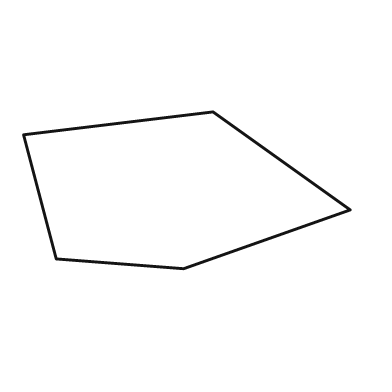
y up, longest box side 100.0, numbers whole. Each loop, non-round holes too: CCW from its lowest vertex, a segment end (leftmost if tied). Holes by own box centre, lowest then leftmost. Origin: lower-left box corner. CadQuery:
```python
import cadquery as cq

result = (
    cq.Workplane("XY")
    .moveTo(49.0, 0.0)
    .lineTo(100.0, 18.0)
    .lineTo(58.0, 48.0)
    .lineTo(0.0, 41.0)
    .lineTo(10.0, 3.0)
    .close()
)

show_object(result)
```